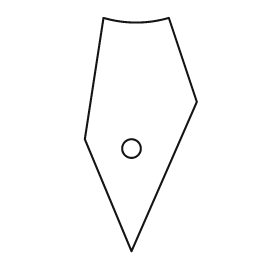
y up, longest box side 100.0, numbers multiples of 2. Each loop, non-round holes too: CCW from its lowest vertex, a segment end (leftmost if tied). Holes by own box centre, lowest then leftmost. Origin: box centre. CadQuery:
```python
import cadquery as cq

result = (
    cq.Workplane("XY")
    .moveTo(-4.0, -50.0)
    .lineTo(24.0, 14.0)
    .lineTo(12.0, 50.0)
    .threePointArc((-2.0, 48.0), (-16.0, 50.0))
    .lineTo(-24.0, -2.0)
    .close()
    .moveTo(-4.0, -6.0)
    .circle(4.0)
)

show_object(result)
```